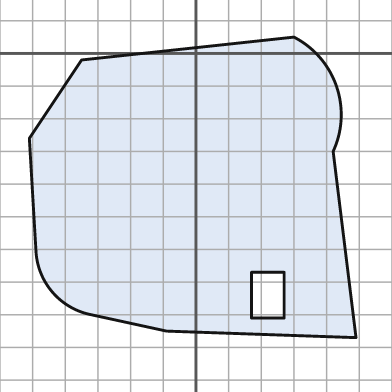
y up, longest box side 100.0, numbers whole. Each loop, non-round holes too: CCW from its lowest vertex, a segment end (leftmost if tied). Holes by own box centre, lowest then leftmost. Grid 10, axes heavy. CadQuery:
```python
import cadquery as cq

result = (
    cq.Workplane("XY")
    .moveTo(49.0, -87.0)
    .lineTo(42.0, -30.0)
    .threePointArc((43.0, -10.0), (30.0, 5.0))
    .lineTo(-35.0, -2.0)
    .lineTo(-51.0, -26.0)
    .lineTo(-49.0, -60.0)
    .threePointArc((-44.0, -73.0), (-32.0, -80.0))
    .lineTo(-9.0, -85.0)
    .close()
    .moveTo(17.0, -81.0)
    .lineTo(27.0, -81.0)
    .lineTo(27.0, -67.0)
    .lineTo(17.0, -67.0)
    .close()
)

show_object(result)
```